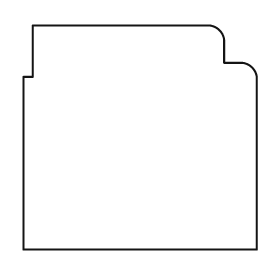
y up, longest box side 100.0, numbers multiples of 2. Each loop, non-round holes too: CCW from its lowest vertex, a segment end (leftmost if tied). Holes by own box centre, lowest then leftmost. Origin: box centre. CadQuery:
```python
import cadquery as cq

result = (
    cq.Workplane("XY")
    .moveTo(-50.0, -48.0)
    .lineTo(50.0, -48.0)
    .lineTo(50.0, 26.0)
    .threePointArc((48.0, 30.0), (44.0, 32.0))
    .lineTo(36.0, 32.0)
    .lineTo(36.0, 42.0)
    .threePointArc((34.0, 46.0), (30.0, 48.0))
    .lineTo(-46.0, 48.0)
    .lineTo(-46.0, 26.0)
    .lineTo(-50.0, 26.0)
    .close()
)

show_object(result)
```